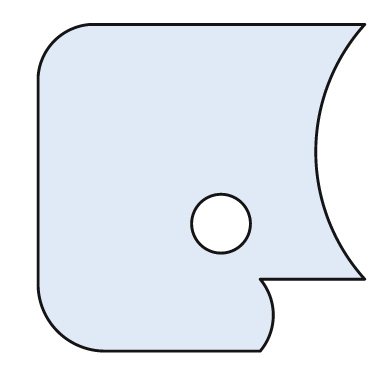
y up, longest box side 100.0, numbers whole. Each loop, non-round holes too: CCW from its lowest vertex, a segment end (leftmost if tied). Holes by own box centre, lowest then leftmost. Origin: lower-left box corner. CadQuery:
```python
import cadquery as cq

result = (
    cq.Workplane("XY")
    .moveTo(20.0, 0.0)
    .lineTo(68.0, 0.0)
    .threePointArc((72.0, 11.0), (68.0, 22.0))
    .lineTo(100.0, 22.0)
    .threePointArc((85.0, 61.0), (100.0, 100.0))
    .lineTo(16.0, 100.0)
    .threePointArc((5.0, 95.0), (0.0, 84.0))
    .lineTo(0.0, 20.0)
    .threePointArc((6.0, 6.0), (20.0, 0.0))
    .close()
    .moveTo(56.0, 39.0)
    .circle(9.0)
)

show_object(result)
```